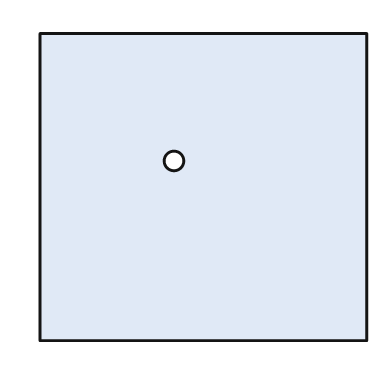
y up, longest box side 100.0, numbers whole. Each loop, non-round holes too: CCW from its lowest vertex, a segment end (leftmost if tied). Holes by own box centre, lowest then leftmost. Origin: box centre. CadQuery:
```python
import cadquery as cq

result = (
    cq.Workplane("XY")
    .moveTo(-50.0, -47.0)
    .lineTo(50.0, -47.0)
    .lineTo(50.0, 47.0)
    .lineTo(-50.0, 47.0)
    .close()
    .moveTo(-9.0, 8.0)
    .circle(3.0)
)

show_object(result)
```